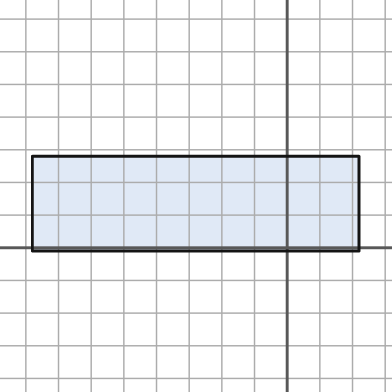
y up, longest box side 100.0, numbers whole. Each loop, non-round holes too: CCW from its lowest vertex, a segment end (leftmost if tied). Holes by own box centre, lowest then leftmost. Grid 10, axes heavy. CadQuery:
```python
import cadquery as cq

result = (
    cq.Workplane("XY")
    .moveTo(-78.0, -1.0)
    .lineTo(22.0, -1.0)
    .lineTo(22.0, 28.0)
    .lineTo(-78.0, 28.0)
    .close()
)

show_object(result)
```